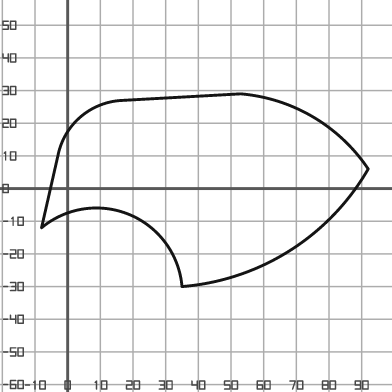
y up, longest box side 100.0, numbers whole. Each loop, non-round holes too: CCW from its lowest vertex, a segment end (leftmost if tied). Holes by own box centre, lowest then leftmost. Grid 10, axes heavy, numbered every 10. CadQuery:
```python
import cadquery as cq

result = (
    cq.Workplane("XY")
    .moveTo(35.0, -30.0)
    .threePointArc((68.0, -19.0), (92.0, 6.0))
    .threePointArc((75.0, 22.0), (53.0, 29.0))
    .lineTo(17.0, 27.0)
    .threePointArc((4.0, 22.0), (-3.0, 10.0))
    .lineTo(-8.0, -12.0)
    .threePointArc((19.0, -8.0), (35.0, -30.0))
    .close()
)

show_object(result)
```